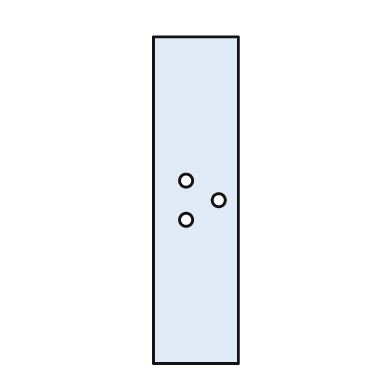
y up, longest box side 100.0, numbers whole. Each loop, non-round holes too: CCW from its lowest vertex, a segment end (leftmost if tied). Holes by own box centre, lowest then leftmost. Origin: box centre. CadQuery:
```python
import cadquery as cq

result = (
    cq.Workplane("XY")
    .moveTo(-13.0, -50.0)
    .lineTo(13.0, -50.0)
    .lineTo(13.0, 50.0)
    .lineTo(-13.0, 50.0)
    .close()
    .moveTo(-3.0, -6.0)
    .circle(2.0)
    .moveTo(7.0, 0.0)
    .circle(2.0)
    .moveTo(-3.0, 6.0)
    .circle(2.0)
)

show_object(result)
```